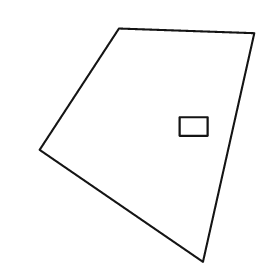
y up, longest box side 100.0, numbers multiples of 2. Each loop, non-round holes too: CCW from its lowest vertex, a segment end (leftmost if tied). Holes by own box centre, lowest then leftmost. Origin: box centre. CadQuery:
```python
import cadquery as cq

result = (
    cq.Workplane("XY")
    .moveTo(24.0, -50.0)
    .lineTo(46.0, 48.0)
    .lineTo(-12.0, 50.0)
    .lineTo(-46.0, -2.0)
    .close()
    .moveTo(14.0, 4.0)
    .lineTo(26.0, 4.0)
    .lineTo(26.0, 12.0)
    .lineTo(14.0, 12.0)
    .close()
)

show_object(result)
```